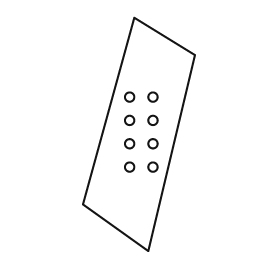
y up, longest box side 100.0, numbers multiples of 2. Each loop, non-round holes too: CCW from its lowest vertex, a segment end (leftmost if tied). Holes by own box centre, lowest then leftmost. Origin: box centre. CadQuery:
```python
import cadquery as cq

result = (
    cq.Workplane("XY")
    .moveTo(4.0, -50.0)
    .lineTo(24.0, 34.0)
    .lineTo(-2.0, 50.0)
    .lineTo(-24.0, -30.0)
    .close()
    .moveTo(-4.0, -14.0)
    .circle(2.0)
    .moveTo(6.0, -14.0)
    .circle(2.0)
    .moveTo(-4.0, -4.0)
    .circle(2.0)
    .moveTo(6.0, -4.0)
    .circle(2.0)
    .moveTo(-4.0, 6.0)
    .circle(2.0)
    .moveTo(6.0, 6.0)
    .circle(2.0)
    .moveTo(-4.0, 16.0)
    .circle(2.0)
    .moveTo(6.0, 16.0)
    .circle(2.0)
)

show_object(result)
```